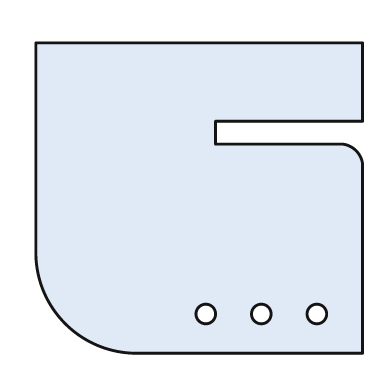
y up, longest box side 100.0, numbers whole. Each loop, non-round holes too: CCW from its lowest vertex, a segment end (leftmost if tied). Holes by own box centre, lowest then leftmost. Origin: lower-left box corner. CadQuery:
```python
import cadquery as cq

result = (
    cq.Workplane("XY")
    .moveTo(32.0, 0.0)
    .lineTo(100.0, 0.0)
    .lineTo(100.0, 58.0)
    .threePointArc((98.0, 62.0), (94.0, 64.0))
    .lineTo(55.0, 64.0)
    .lineTo(55.0, 71.0)
    .lineTo(100.0, 71.0)
    .lineTo(100.0, 95.0)
    .lineTo(0.0, 95.0)
    .lineTo(0.0, 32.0)
    .threePointArc((9.0, 9.0), (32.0, 0.0))
    .close()
    .moveTo(52.0, 12.0)
    .circle(3.0)
    .moveTo(69.0, 12.0)
    .circle(3.0)
    .moveTo(86.0, 12.0)
    .circle(3.0)
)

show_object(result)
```